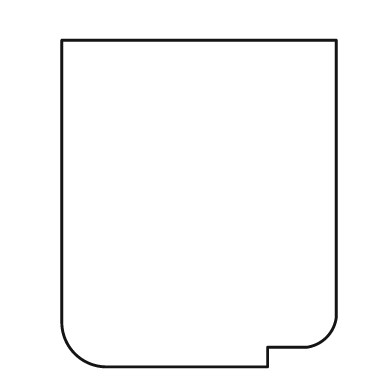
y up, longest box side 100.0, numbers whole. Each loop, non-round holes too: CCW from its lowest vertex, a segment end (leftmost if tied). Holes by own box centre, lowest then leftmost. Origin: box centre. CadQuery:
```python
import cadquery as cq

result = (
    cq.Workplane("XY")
    .moveTo(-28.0, -50.0)
    .lineTo(21.0, -50.0)
    .lineTo(21.0, -44.0)
    .lineTo(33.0, -44.0)
    .threePointArc((39.0, -41.0), (42.0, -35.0))
    .lineTo(42.0, 50.0)
    .lineTo(-42.0, 50.0)
    .lineTo(-42.0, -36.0)
    .threePointArc((-38.0, -46.0), (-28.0, -50.0))
    .close()
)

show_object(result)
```